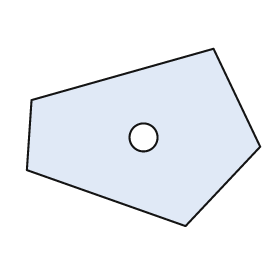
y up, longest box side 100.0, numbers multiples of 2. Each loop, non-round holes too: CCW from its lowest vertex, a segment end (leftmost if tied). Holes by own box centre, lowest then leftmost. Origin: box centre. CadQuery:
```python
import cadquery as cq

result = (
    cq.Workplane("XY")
    .moveTo(18.0, -38.0)
    .lineTo(50.0, -4.0)
    .lineTo(30.0, 38.0)
    .lineTo(-48.0, 16.0)
    .lineTo(-50.0, -14.0)
    .close()
    .moveTo(0.0, 0.0)
    .circle(6.0)
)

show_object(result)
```